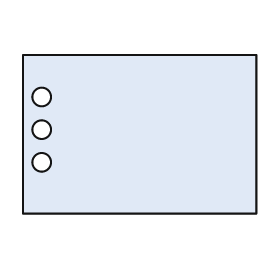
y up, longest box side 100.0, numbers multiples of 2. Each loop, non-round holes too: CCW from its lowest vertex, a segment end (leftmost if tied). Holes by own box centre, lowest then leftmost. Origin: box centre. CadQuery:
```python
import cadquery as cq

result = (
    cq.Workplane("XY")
    .moveTo(-50.0, -34.0)
    .lineTo(50.0, -34.0)
    .lineTo(50.0, 34.0)
    .lineTo(-50.0, 34.0)
    .close()
    .moveTo(-42.0, -12.0)
    .circle(4.0)
    .moveTo(-42.0, 2.0)
    .circle(4.0)
    .moveTo(-42.0, 16.0)
    .circle(4.0)
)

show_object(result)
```